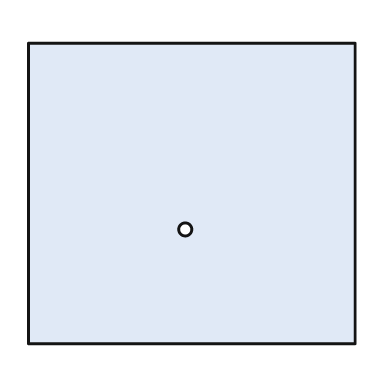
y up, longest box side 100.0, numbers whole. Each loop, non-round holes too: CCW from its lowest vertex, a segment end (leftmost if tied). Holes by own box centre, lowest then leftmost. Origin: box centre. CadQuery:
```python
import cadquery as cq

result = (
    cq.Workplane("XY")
    .moveTo(-50.0, -46.0)
    .lineTo(50.0, -46.0)
    .lineTo(50.0, 46.0)
    .lineTo(-50.0, 46.0)
    .close()
    .moveTo(-2.0, -11.0)
    .circle(2.0)
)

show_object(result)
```